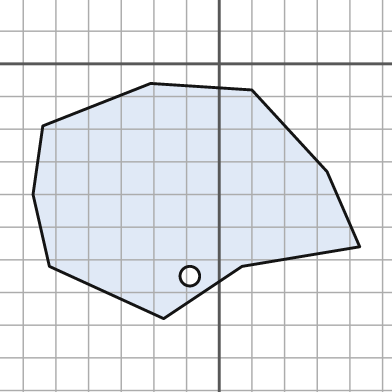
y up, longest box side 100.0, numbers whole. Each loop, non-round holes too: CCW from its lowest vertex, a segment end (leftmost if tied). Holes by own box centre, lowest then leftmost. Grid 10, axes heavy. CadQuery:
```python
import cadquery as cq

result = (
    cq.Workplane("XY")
    .moveTo(-17.0, -78.0)
    .lineTo(7.0, -62.0)
    .lineTo(43.0, -56.0)
    .lineTo(33.0, -33.0)
    .lineTo(10.0, -8.0)
    .lineTo(-21.0, -6.0)
    .lineTo(-54.0, -19.0)
    .lineTo(-57.0, -40.0)
    .lineTo(-52.0, -62.0)
    .close()
    .moveTo(-9.0, -65.0)
    .circle(3.0)
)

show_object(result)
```